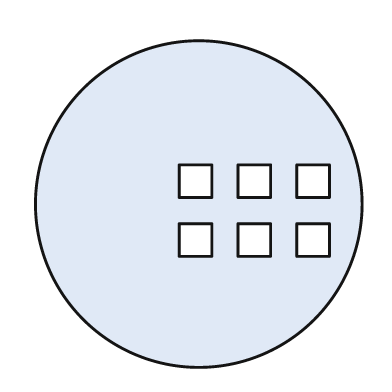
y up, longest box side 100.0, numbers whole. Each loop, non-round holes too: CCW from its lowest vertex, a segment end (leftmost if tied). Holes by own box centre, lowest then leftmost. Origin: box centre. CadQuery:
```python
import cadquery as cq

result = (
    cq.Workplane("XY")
    .moveTo(0.0, 0.0)
    .circle(50.0)
    .moveTo(-6.0, -16.0)
    .lineTo(4.0, -16.0)
    .lineTo(4.0, -6.0)
    .lineTo(-6.0, -6.0)
    .close()
    .moveTo(12.0, -16.0)
    .lineTo(22.0, -16.0)
    .lineTo(22.0, -6.0)
    .lineTo(12.0, -6.0)
    .close()
    .moveTo(30.0, -16.0)
    .lineTo(40.0, -16.0)
    .lineTo(40.0, -6.0)
    .lineTo(30.0, -6.0)
    .close()
    .moveTo(-6.0, 2.0)
    .lineTo(4.0, 2.0)
    .lineTo(4.0, 12.0)
    .lineTo(-6.0, 12.0)
    .close()
    .moveTo(12.0, 2.0)
    .lineTo(22.0, 2.0)
    .lineTo(22.0, 12.0)
    .lineTo(12.0, 12.0)
    .close()
    .moveTo(30.0, 2.0)
    .lineTo(40.0, 2.0)
    .lineTo(40.0, 12.0)
    .lineTo(30.0, 12.0)
    .close()
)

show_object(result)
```